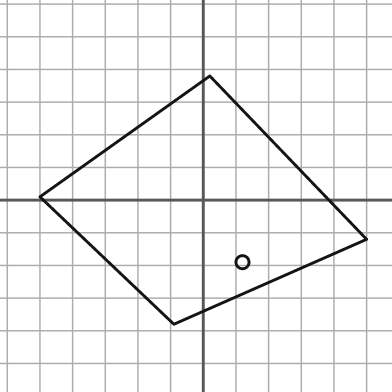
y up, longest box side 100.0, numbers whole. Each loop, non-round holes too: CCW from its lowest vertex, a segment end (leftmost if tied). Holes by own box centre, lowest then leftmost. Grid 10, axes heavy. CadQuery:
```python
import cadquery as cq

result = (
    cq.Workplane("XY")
    .moveTo(-9.0, -38.0)
    .lineTo(50.0, -12.0)
    .lineTo(2.0, 38.0)
    .lineTo(-50.0, 1.0)
    .close()
    .moveTo(12.0, -19.0)
    .circle(2.0)
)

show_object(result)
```